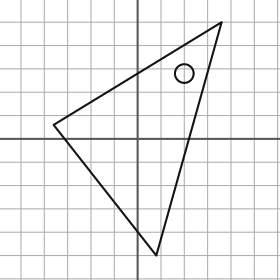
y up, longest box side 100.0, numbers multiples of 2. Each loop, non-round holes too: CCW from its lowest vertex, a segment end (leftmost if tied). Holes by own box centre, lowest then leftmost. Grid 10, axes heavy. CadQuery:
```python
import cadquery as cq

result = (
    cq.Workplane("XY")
    .moveTo(8.0, -50.0)
    .lineTo(36.0, 50.0)
    .lineTo(-36.0, 6.0)
    .close()
    .moveTo(20.0, 28.0)
    .circle(4.0)
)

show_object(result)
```